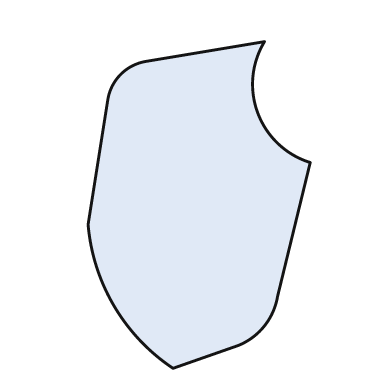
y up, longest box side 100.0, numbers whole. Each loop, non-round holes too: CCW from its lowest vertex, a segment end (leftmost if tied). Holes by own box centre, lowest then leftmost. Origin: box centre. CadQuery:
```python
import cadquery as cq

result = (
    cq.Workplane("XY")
    .moveTo(-8.0, -50.0)
    .lineTo(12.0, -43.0)
    .threePointArc((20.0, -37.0), (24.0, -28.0))
    .lineTo(34.0, 13.0)
    .threePointArc((18.0, 28.0), (20.0, 50.0))
    .lineTo(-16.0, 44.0)
    .threePointArc((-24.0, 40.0), (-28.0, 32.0))
    .lineTo(-34.0, -6.0)
    .threePointArc((-26.0, -31.0), (-8.0, -50.0))
    .close()
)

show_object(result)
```